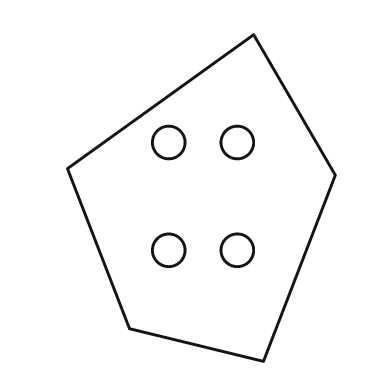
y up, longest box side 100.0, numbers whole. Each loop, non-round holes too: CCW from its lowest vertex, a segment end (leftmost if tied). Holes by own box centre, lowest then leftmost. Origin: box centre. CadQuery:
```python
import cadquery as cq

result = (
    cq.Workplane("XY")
    .moveTo(19.0, -50.0)
    .lineTo(41.0, 7.0)
    .lineTo(16.0, 50.0)
    .lineTo(-41.0, 9.0)
    .lineTo(-22.0, -40.0)
    .close()
    .moveTo(-10.0, -16.0)
    .circle(5.0)
    .moveTo(11.0, -16.0)
    .circle(5.0)
    .moveTo(-10.0, 17.0)
    .circle(5.0)
    .moveTo(11.0, 17.0)
    .circle(5.0)
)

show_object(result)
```